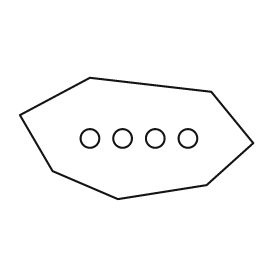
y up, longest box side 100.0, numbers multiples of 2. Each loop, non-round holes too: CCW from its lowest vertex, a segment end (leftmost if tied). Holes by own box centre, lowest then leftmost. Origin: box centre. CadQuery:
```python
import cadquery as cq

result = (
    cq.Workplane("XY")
    .moveTo(-8.0, -26.0)
    .lineTo(30.0, -20.0)
    .lineTo(50.0, -2.0)
    .lineTo(32.0, 20.0)
    .lineTo(-20.0, 26.0)
    .lineTo(-50.0, 10.0)
    .lineTo(-36.0, -14.0)
    .close()
    .moveTo(-20.0, 0.0)
    .circle(4.0)
    .moveTo(-6.0, 0.0)
    .circle(4.0)
    .moveTo(8.0, 0.0)
    .circle(4.0)
    .moveTo(22.0, 0.0)
    .circle(4.0)
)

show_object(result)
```